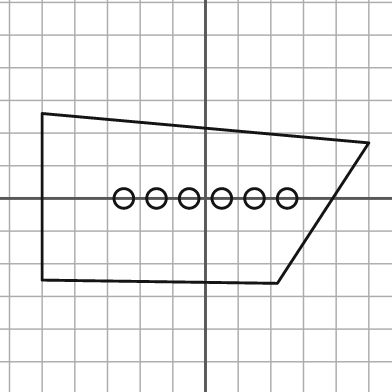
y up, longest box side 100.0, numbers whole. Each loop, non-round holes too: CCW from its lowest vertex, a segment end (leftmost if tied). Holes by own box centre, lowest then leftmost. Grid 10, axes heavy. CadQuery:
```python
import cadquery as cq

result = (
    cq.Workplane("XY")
    .moveTo(22.0, -26.0)
    .lineTo(50.0, 17.0)
    .lineTo(-50.0, 26.0)
    .lineTo(-50.0, -25.0)
    .close()
    .moveTo(-25.0, 0.0)
    .circle(3.0)
    .moveTo(-15.0, 0.0)
    .circle(3.0)
    .moveTo(-5.0, 0.0)
    .circle(3.0)
    .moveTo(5.0, 0.0)
    .circle(3.0)
    .moveTo(15.0, 0.0)
    .circle(3.0)
    .moveTo(25.0, 0.0)
    .circle(3.0)
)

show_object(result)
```